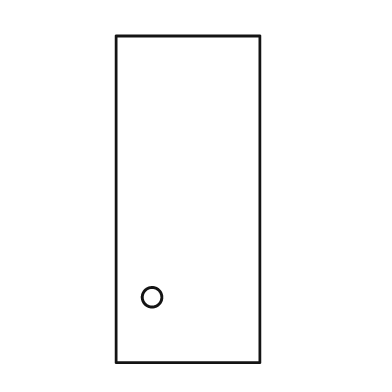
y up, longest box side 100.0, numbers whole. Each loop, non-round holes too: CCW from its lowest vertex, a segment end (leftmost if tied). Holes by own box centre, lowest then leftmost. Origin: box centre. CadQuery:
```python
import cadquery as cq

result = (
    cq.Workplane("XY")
    .moveTo(-22.0, -50.0)
    .lineTo(22.0, -50.0)
    .lineTo(22.0, 50.0)
    .lineTo(-22.0, 50.0)
    .close()
    .moveTo(-11.0, -30.0)
    .circle(3.0)
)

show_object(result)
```